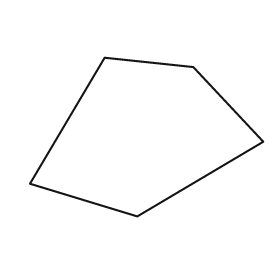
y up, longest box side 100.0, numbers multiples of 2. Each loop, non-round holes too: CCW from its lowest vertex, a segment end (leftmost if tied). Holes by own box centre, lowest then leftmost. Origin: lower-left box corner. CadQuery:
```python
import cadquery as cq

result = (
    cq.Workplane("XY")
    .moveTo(46.0, 0.0)
    .lineTo(100.0, 32.0)
    .lineTo(70.0, 64.0)
    .lineTo(32.0, 68.0)
    .lineTo(0.0, 14.0)
    .close()
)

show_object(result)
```